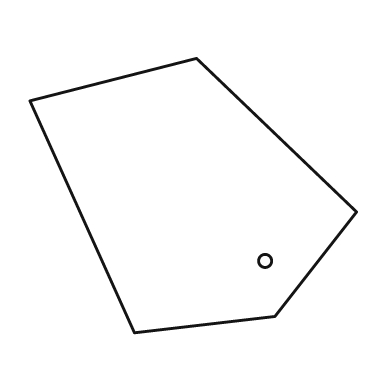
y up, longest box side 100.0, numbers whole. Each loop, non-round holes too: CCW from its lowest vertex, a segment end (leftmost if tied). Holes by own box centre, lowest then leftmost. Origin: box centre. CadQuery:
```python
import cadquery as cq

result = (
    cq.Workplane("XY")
    .moveTo(-18.0, -42.0)
    .lineTo(25.0, -37.0)
    .lineTo(50.0, -5.0)
    .lineTo(1.0, 42.0)
    .lineTo(-50.0, 29.0)
    .close()
    .moveTo(22.0, -20.0)
    .circle(2.0)
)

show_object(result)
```